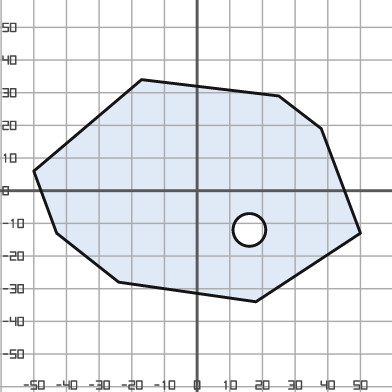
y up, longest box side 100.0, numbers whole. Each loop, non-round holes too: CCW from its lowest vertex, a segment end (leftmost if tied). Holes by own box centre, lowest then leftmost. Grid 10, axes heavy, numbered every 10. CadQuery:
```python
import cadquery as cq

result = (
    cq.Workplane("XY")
    .moveTo(18.0, -34.0)
    .lineTo(50.0, -13.0)
    .lineTo(38.0, 19.0)
    .lineTo(25.0, 29.0)
    .lineTo(-17.0, 34.0)
    .lineTo(-50.0, 6.0)
    .lineTo(-43.0, -13.0)
    .lineTo(-24.0, -28.0)
    .close()
    .moveTo(16.0, -12.0)
    .circle(5.0)
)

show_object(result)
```